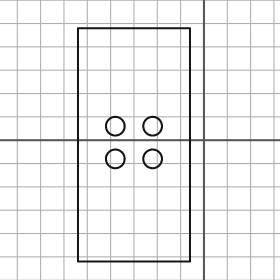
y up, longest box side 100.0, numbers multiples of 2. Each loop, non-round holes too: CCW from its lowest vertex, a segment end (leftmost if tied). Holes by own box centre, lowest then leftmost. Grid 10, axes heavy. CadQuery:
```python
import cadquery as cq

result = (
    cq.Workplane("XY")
    .moveTo(-54.0, -52.0)
    .lineTo(-6.0, -52.0)
    .lineTo(-6.0, 48.0)
    .lineTo(-54.0, 48.0)
    .close()
    .moveTo(-38.0, -8.0)
    .circle(4.0)
    .moveTo(-22.0, -8.0)
    .circle(4.0)
    .moveTo(-38.0, 6.0)
    .circle(4.0)
    .moveTo(-22.0, 6.0)
    .circle(4.0)
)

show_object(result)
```